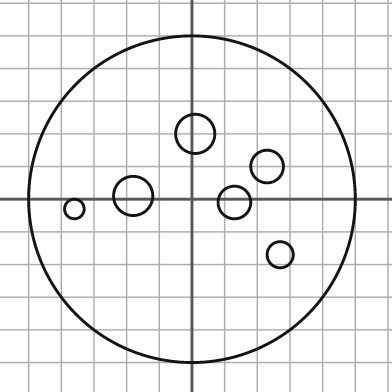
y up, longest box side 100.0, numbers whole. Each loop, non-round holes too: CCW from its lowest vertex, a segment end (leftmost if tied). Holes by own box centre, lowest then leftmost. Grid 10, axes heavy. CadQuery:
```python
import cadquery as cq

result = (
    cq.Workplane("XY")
    .moveTo(0.0, 0.0)
    .circle(50.0)
    .moveTo(27.0, -17.0)
    .circle(4.0)
    .moveTo(-36.0, -3.0)
    .circle(3.0)
    .moveTo(13.0, -1.0)
    .circle(5.0)
    .moveTo(-18.0, 1.0)
    .circle(6.0)
    .moveTo(23.0, 10.0)
    .circle(5.0)
    .moveTo(1.0, 20.0)
    .circle(6.0)
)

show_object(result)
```